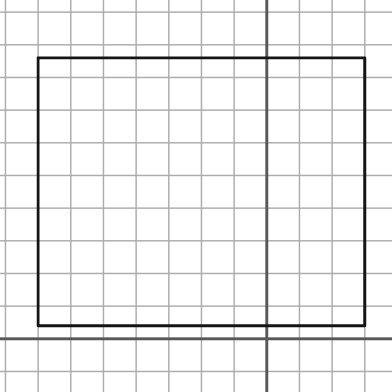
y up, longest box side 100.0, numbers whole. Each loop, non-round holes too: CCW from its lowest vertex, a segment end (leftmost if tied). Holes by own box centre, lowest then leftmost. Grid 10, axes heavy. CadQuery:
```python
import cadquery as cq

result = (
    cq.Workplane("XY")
    .moveTo(-70.0, 4.0)
    .lineTo(30.0, 4.0)
    .lineTo(30.0, 86.0)
    .lineTo(-70.0, 86.0)
    .close()
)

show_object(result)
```